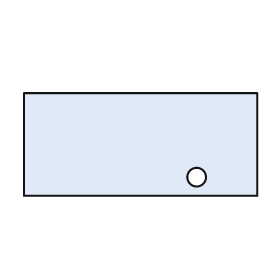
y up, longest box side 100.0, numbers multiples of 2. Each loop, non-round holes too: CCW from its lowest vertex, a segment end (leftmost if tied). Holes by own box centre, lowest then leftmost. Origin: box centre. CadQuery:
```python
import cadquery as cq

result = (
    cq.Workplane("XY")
    .moveTo(-50.0, -22.0)
    .lineTo(50.0, -22.0)
    .lineTo(50.0, 22.0)
    .lineTo(-50.0, 22.0)
    .close()
    .moveTo(24.0, -14.0)
    .circle(4.0)
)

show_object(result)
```